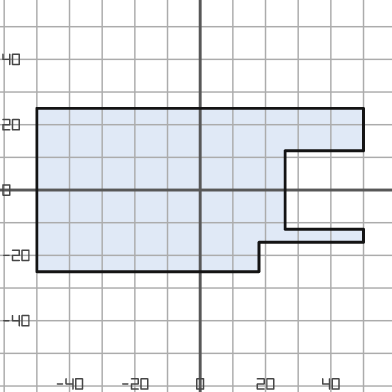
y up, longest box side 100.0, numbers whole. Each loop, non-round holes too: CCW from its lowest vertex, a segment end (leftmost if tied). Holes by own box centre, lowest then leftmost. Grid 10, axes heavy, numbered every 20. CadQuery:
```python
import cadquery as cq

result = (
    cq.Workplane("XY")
    .moveTo(-50.0, -25.0)
    .lineTo(18.0, -25.0)
    .lineTo(18.0, -16.0)
    .lineTo(50.0, -16.0)
    .lineTo(50.0, -12.0)
    .lineTo(26.0, -12.0)
    .lineTo(26.0, 12.0)
    .lineTo(50.0, 12.0)
    .lineTo(50.0, 25.0)
    .lineTo(-50.0, 25.0)
    .close()
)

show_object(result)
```